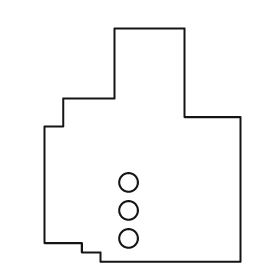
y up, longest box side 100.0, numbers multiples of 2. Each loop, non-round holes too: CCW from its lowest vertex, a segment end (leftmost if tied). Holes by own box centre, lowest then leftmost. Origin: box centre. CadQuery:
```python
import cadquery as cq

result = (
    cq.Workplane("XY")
    .moveTo(-18.0, -50.0)
    .lineTo(42.0, -50.0)
    .lineTo(42.0, 12.0)
    .lineTo(18.0, 12.0)
    .lineTo(18.0, 50.0)
    .lineTo(-12.0, 50.0)
    .lineTo(-12.0, 20.0)
    .lineTo(-34.0, 20.0)
    .lineTo(-34.0, 8.0)
    .lineTo(-42.0, 8.0)
    .lineTo(-42.0, -42.0)
    .lineTo(-26.0, -42.0)
    .lineTo(-26.0, -46.0)
    .lineTo(-18.0, -46.0)
    .close()
    .moveTo(-6.0, -40.0)
    .circle(4.0)
    .moveTo(-6.0, -28.0)
    .circle(4.0)
    .moveTo(-6.0, -16.0)
    .circle(4.0)
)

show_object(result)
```